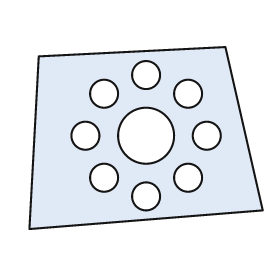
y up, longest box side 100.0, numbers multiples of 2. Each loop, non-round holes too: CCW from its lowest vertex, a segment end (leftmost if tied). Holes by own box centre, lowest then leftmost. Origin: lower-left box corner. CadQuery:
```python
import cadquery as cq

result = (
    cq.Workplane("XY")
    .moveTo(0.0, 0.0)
    .lineTo(100.0, 8.0)
    .lineTo(84.0, 78.0)
    .lineTo(4.0, 74.0)
    .close()
    .moveTo(50.0, 14.0)
    .circle(6.0)
    .moveTo(32.0, 22.0)
    .circle(6.0)
    .moveTo(68.0, 22.0)
    .circle(6.0)
    .moveTo(24.0, 40.0)
    .circle(6.0)
    .moveTo(50.0, 40.0)
    .circle(12.0)
    .moveTo(76.0, 40.0)
    .circle(6.0)
    .moveTo(32.0, 58.0)
    .circle(6.0)
    .moveTo(68.0, 58.0)
    .circle(6.0)
    .moveTo(50.0, 66.0)
    .circle(6.0)
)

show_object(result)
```